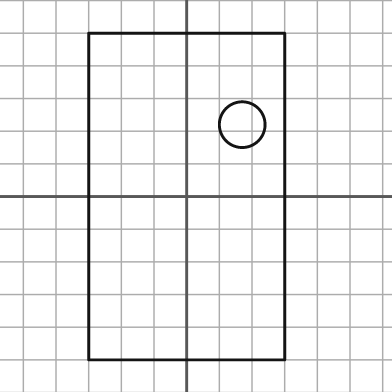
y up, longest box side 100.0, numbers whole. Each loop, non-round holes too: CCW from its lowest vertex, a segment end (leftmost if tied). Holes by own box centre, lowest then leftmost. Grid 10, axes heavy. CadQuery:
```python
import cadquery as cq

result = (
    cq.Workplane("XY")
    .moveTo(-30.0, -50.0)
    .lineTo(30.0, -50.0)
    .lineTo(30.0, 50.0)
    .lineTo(-30.0, 50.0)
    .close()
    .moveTo(17.0, 22.0)
    .circle(7.0)
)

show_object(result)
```